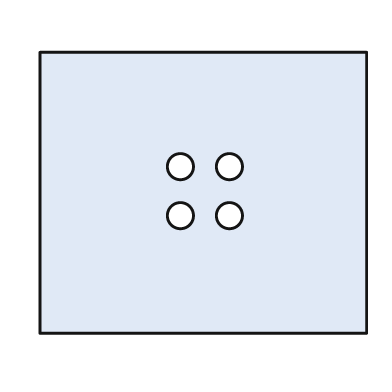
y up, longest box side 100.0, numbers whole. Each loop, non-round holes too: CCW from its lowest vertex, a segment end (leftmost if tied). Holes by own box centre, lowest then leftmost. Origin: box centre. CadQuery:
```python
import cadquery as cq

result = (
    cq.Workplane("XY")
    .moveTo(-50.0, -43.0)
    .lineTo(50.0, -43.0)
    .lineTo(50.0, 43.0)
    .lineTo(-50.0, 43.0)
    .close()
    .moveTo(-7.0, -7.0)
    .circle(4.0)
    .moveTo(8.0, -7.0)
    .circle(4.0)
    .moveTo(-7.0, 8.0)
    .circle(4.0)
    .moveTo(8.0, 8.0)
    .circle(4.0)
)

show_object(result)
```